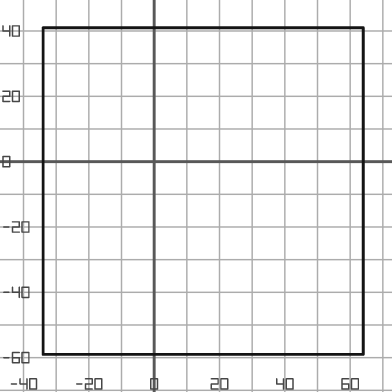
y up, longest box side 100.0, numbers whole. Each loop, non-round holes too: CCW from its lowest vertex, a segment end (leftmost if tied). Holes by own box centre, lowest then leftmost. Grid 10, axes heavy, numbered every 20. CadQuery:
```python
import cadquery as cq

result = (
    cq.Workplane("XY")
    .moveTo(-34.0, -59.0)
    .lineTo(64.0, -59.0)
    .lineTo(64.0, 41.0)
    .lineTo(-34.0, 41.0)
    .close()
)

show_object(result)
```